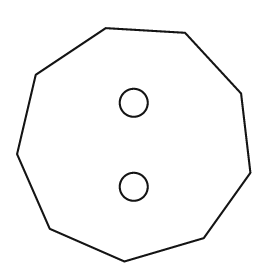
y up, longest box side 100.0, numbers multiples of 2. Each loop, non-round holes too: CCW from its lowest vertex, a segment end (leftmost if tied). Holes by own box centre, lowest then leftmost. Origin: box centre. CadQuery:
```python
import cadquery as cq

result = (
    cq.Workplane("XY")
    .moveTo(-4.0, -50.0)
    .lineTo(30.0, -40.0)
    .lineTo(50.0, -12.0)
    .lineTo(46.0, 22.0)
    .lineTo(22.0, 48.0)
    .lineTo(-12.0, 50.0)
    .lineTo(-42.0, 30.0)
    .lineTo(-50.0, -4.0)
    .lineTo(-36.0, -36.0)
    .close()
    .moveTo(0.0, -18.0)
    .circle(6.0)
    .moveTo(0.0, 18.0)
    .circle(6.0)
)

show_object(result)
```